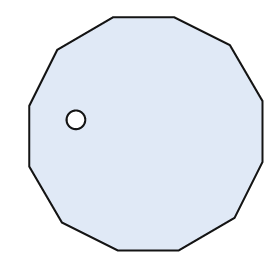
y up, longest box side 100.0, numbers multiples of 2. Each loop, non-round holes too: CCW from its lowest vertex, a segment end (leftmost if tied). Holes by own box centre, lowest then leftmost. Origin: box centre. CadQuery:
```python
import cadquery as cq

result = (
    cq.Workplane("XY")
    .moveTo(-12.0, -50.0)
    .lineTo(14.0, -50.0)
    .lineTo(38.0, -36.0)
    .lineTo(50.0, -12.0)
    .lineTo(50.0, 14.0)
    .lineTo(36.0, 38.0)
    .lineTo(12.0, 50.0)
    .lineTo(-14.0, 50.0)
    .lineTo(-38.0, 36.0)
    .lineTo(-50.0, 12.0)
    .lineTo(-50.0, -14.0)
    .lineTo(-36.0, -38.0)
    .close()
    .moveTo(-30.0, 6.0)
    .circle(4.0)
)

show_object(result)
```